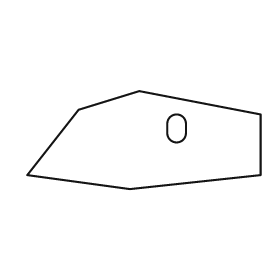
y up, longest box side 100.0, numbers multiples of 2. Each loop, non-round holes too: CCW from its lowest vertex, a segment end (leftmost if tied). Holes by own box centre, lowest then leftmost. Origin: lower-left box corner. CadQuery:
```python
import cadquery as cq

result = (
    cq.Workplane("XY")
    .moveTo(44.0, 0.0)
    .lineTo(100.0, 6.0)
    .lineTo(100.0, 32.0)
    .lineTo(48.0, 42.0)
    .lineTo(22.0, 34.0)
    .lineTo(0.0, 6.0)
    .close()
    .moveTo(60.0, 24.0)
    .threePointArc((64.0, 20.0), (68.0, 24.0))
    .lineTo(68.0, 28.0)
    .threePointArc((64.0, 32.0), (60.0, 28.0))
    .close()
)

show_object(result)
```